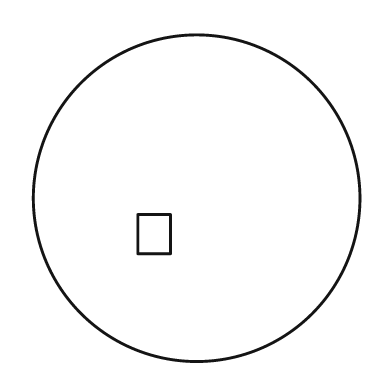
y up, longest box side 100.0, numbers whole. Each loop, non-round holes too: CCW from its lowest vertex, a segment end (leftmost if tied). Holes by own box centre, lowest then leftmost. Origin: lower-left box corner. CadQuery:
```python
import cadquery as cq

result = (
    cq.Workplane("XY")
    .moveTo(50.0, 50.0)
    .circle(50.0)
    .moveTo(32.0, 33.0)
    .lineTo(42.0, 33.0)
    .lineTo(42.0, 45.0)
    .lineTo(32.0, 45.0)
    .close()
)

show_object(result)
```